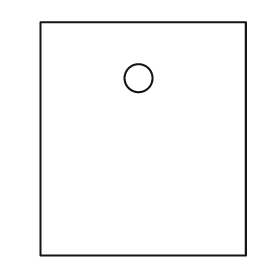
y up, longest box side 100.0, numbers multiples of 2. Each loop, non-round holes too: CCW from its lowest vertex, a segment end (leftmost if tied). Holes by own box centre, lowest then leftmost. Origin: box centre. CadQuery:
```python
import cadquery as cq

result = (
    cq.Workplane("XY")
    .moveTo(-44.0, -50.0)
    .lineTo(44.0, -50.0)
    .lineTo(44.0, 50.0)
    .lineTo(-44.0, 50.0)
    .close()
    .moveTo(-2.0, 26.0)
    .circle(6.0)
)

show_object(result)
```